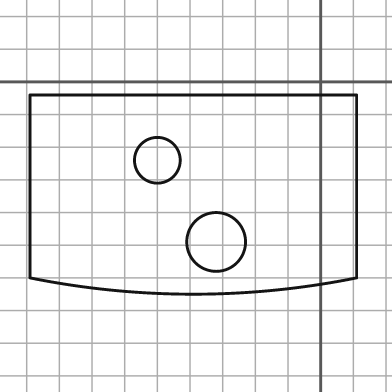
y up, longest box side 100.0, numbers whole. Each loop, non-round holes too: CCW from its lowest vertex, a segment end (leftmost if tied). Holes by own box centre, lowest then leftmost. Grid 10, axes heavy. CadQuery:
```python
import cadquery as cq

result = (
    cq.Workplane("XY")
    .moveTo(-89.0, -60.0)
    .threePointArc((-39.0, -65.0), (11.0, -60.0))
    .lineTo(11.0, -4.0)
    .lineTo(-89.0, -4.0)
    .close()
    .moveTo(-32.0, -49.0)
    .circle(9.0)
    .moveTo(-50.0, -24.0)
    .circle(7.0)
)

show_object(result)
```